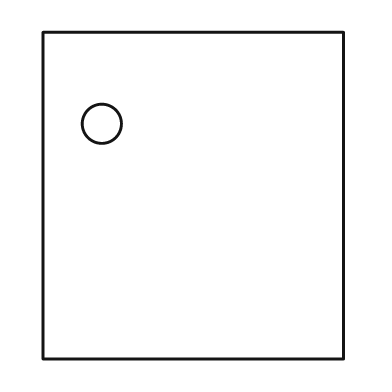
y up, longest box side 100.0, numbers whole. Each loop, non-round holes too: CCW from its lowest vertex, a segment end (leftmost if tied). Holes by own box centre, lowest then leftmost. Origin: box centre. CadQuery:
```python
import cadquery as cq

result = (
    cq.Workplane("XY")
    .moveTo(-46.0, -50.0)
    .lineTo(46.0, -50.0)
    .lineTo(46.0, 50.0)
    .lineTo(-46.0, 50.0)
    .close()
    .moveTo(-28.0, 22.0)
    .circle(6.0)
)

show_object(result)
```